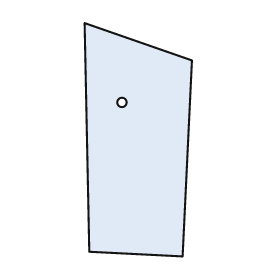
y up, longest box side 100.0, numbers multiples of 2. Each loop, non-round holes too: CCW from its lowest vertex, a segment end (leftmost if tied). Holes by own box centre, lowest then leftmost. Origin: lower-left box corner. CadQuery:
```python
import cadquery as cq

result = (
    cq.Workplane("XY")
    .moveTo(42.0, 0.0)
    .lineTo(46.0, 84.0)
    .lineTo(0.0, 100.0)
    .lineTo(2.0, 2.0)
    .close()
    .moveTo(16.0, 66.0)
    .circle(2.0)
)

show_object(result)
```